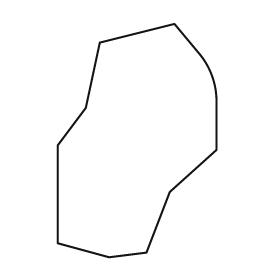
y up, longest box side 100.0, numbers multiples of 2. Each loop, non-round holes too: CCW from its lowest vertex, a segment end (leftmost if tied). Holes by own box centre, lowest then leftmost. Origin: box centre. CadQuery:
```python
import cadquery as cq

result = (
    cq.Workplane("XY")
    .moveTo(-12.0, -50.0)
    .lineTo(4.0, -48.0)
    .lineTo(14.0, -22.0)
    .lineTo(34.0, -4.0)
    .lineTo(34.0, 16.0)
    .threePointArc((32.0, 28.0), (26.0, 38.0))
    .lineTo(16.0, 50.0)
    .lineTo(-16.0, 42.0)
    .lineTo(-22.0, 14.0)
    .lineTo(-34.0, -2.0)
    .lineTo(-34.0, -44.0)
    .close()
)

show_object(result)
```